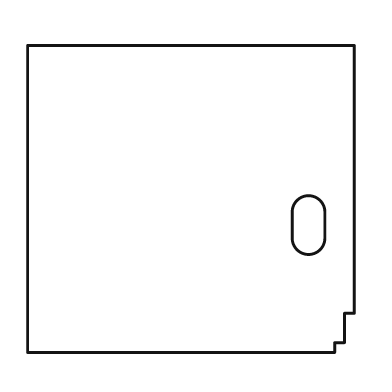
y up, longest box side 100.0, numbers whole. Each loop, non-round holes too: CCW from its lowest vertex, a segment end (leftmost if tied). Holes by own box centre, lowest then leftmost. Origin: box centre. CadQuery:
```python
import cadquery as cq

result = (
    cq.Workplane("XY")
    .moveTo(-50.0, -47.0)
    .lineTo(44.0, -47.0)
    .lineTo(44.0, -44.0)
    .lineTo(47.0, -44.0)
    .lineTo(47.0, -35.0)
    .lineTo(50.0, -35.0)
    .lineTo(50.0, 47.0)
    .lineTo(-50.0, 47.0)
    .close()
    .moveTo(31.0, -12.0)
    .threePointArc((36.0, -17.0), (41.0, -12.0))
    .lineTo(41.0, -4.0)
    .threePointArc((36.0, 1.0), (31.0, -4.0))
    .close()
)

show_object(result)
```